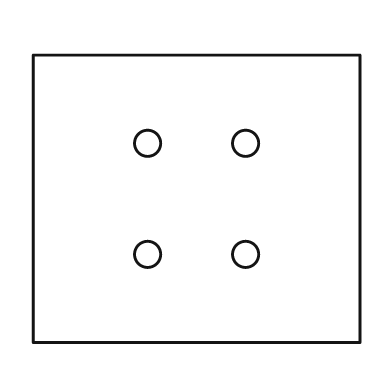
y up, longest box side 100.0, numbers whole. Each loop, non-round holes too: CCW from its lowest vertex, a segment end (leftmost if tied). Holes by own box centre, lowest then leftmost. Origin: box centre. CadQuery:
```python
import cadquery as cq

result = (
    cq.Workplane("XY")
    .moveTo(-50.0, -44.0)
    .lineTo(50.0, -44.0)
    .lineTo(50.0, 44.0)
    .lineTo(-50.0, 44.0)
    .close()
    .moveTo(-15.0, -17.0)
    .circle(4.0)
    .moveTo(15.0, -17.0)
    .circle(4.0)
    .moveTo(-15.0, 17.0)
    .circle(4.0)
    .moveTo(15.0, 17.0)
    .circle(4.0)
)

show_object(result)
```